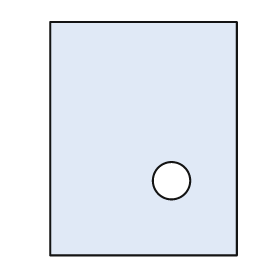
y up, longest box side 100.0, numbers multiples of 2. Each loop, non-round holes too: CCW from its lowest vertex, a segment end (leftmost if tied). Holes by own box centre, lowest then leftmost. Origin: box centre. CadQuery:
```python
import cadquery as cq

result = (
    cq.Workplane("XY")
    .moveTo(-40.0, -50.0)
    .lineTo(40.0, -50.0)
    .lineTo(40.0, 50.0)
    .lineTo(-40.0, 50.0)
    .close()
    .moveTo(12.0, -18.0)
    .circle(8.0)
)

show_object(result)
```